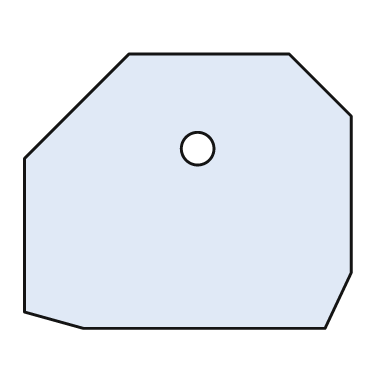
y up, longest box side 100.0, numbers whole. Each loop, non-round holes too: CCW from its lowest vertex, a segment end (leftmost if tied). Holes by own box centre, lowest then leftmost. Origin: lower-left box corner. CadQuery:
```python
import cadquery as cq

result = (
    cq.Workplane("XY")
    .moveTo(18.0, 0.0)
    .lineTo(92.0, 0.0)
    .lineTo(100.0, 17.0)
    .lineTo(100.0, 65.0)
    .lineTo(81.0, 84.0)
    .lineTo(32.0, 84.0)
    .lineTo(0.0, 52.0)
    .lineTo(0.0, 5.0)
    .close()
    .moveTo(53.0, 55.0)
    .circle(5.0)
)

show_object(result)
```